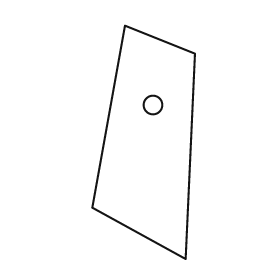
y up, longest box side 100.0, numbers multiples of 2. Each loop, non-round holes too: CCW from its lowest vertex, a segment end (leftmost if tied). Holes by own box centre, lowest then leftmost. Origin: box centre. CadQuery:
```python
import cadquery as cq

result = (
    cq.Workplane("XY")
    .moveTo(18.0, -50.0)
    .lineTo(22.0, 38.0)
    .lineTo(-8.0, 50.0)
    .lineTo(-22.0, -28.0)
    .close()
    .moveTo(4.0, 16.0)
    .circle(4.0)
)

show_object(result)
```